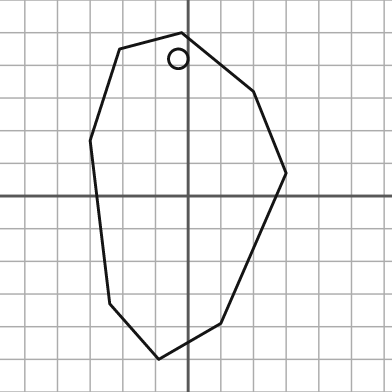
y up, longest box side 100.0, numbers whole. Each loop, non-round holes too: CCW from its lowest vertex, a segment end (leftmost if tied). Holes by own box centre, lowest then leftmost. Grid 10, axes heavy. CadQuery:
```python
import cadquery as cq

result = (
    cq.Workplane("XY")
    .moveTo(-9.0, -50.0)
    .lineTo(10.0, -39.0)
    .lineTo(30.0, 7.0)
    .lineTo(20.0, 32.0)
    .lineTo(-2.0, 50.0)
    .lineTo(-21.0, 45.0)
    .lineTo(-30.0, 17.0)
    .lineTo(-24.0, -33.0)
    .close()
    .moveTo(-3.0, 42.0)
    .circle(3.0)
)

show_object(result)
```